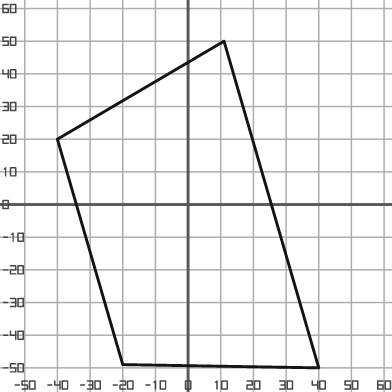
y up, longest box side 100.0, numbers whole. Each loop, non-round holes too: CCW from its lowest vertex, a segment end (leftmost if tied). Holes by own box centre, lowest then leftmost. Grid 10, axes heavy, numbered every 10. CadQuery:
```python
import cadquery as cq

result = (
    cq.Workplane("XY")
    .moveTo(40.0, -50.0)
    .lineTo(11.0, 50.0)
    .lineTo(-40.0, 20.0)
    .lineTo(-20.0, -49.0)
    .close()
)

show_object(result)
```